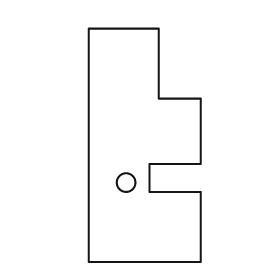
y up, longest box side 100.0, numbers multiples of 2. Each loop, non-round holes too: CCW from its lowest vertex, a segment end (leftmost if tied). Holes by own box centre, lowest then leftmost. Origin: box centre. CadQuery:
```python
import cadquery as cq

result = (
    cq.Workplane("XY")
    .moveTo(-24.0, -50.0)
    .lineTo(24.0, -50.0)
    .lineTo(24.0, -20.0)
    .lineTo(2.0, -20.0)
    .lineTo(2.0, -8.0)
    .lineTo(24.0, -8.0)
    .lineTo(24.0, 20.0)
    .lineTo(6.0, 20.0)
    .lineTo(6.0, 50.0)
    .lineTo(-24.0, 50.0)
    .close()
    .moveTo(-8.0, -16.0)
    .circle(4.0)
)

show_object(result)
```